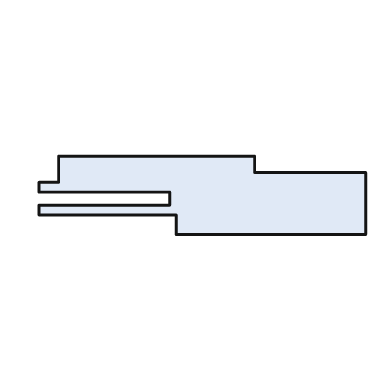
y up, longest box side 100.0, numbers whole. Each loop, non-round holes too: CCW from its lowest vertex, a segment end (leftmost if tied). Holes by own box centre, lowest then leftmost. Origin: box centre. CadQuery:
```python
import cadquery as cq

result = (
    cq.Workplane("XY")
    .moveTo(-8.0, -12.0)
    .lineTo(50.0, -12.0)
    .lineTo(50.0, 7.0)
    .lineTo(16.0, 7.0)
    .lineTo(16.0, 12.0)
    .lineTo(-44.0, 12.0)
    .lineTo(-44.0, 4.0)
    .lineTo(-50.0, 4.0)
    .lineTo(-50.0, 1.0)
    .lineTo(-10.0, 1.0)
    .lineTo(-10.0, -3.0)
    .lineTo(-50.0, -3.0)
    .lineTo(-50.0, -6.0)
    .lineTo(-8.0, -6.0)
    .close()
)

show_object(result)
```